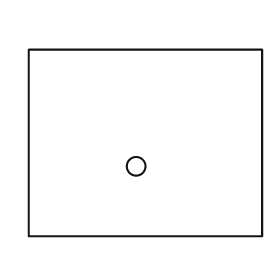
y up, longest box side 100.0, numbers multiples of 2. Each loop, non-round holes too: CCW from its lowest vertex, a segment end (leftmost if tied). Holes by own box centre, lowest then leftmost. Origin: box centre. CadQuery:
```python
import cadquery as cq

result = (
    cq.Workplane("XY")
    .moveTo(-50.0, -40.0)
    .lineTo(50.0, -40.0)
    .lineTo(50.0, 40.0)
    .lineTo(-50.0, 40.0)
    .close()
    .moveTo(-4.0, -10.0)
    .circle(4.0)
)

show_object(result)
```